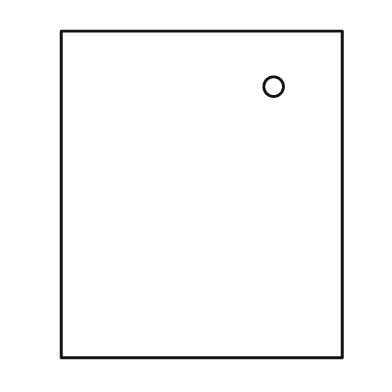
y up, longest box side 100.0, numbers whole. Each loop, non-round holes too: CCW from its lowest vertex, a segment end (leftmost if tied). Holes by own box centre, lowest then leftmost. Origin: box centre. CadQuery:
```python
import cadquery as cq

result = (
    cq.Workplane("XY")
    .moveTo(-43.0, -50.0)
    .lineTo(43.0, -50.0)
    .lineTo(43.0, 50.0)
    .lineTo(-43.0, 50.0)
    .close()
    .moveTo(22.0, 33.0)
    .circle(3.0)
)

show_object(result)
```